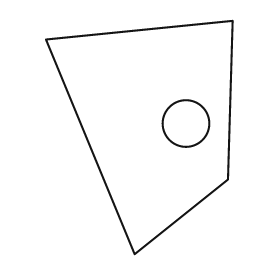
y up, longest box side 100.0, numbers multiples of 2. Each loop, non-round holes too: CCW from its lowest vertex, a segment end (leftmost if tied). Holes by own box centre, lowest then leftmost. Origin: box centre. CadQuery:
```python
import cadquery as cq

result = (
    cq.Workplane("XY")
    .moveTo(-2.0, -50.0)
    .lineTo(38.0, -18.0)
    .lineTo(40.0, 50.0)
    .lineTo(-40.0, 42.0)
    .close()
    .moveTo(20.0, 6.0)
    .circle(10.0)
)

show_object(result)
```